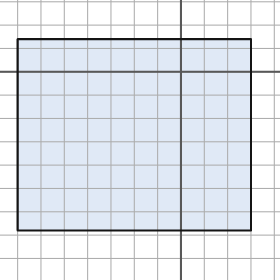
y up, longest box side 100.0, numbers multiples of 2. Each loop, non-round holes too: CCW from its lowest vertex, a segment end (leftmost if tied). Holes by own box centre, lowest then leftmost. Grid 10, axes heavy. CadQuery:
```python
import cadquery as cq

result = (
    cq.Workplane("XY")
    .moveTo(-70.0, -68.0)
    .lineTo(30.0, -68.0)
    .lineTo(30.0, 14.0)
    .lineTo(-70.0, 14.0)
    .close()
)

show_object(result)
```